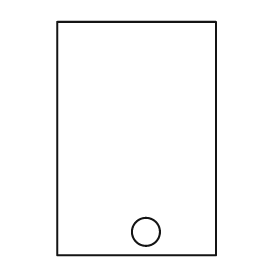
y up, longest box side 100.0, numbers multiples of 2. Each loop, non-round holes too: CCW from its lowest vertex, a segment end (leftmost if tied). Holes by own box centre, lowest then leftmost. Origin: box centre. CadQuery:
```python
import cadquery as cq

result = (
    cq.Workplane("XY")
    .moveTo(-34.0, -50.0)
    .lineTo(34.0, -50.0)
    .lineTo(34.0, 50.0)
    .lineTo(-34.0, 50.0)
    .close()
    .moveTo(4.0, -40.0)
    .circle(6.0)
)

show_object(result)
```